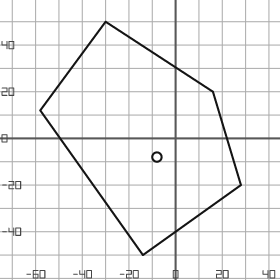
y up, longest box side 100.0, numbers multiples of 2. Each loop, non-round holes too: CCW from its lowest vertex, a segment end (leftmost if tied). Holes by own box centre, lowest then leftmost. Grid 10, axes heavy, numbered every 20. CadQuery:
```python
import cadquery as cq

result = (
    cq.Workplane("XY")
    .moveTo(-14.0, -50.0)
    .lineTo(28.0, -20.0)
    .lineTo(16.0, 20.0)
    .lineTo(-30.0, 50.0)
    .lineTo(-58.0, 12.0)
    .close()
    .moveTo(-8.0, -8.0)
    .circle(2.0)
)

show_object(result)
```